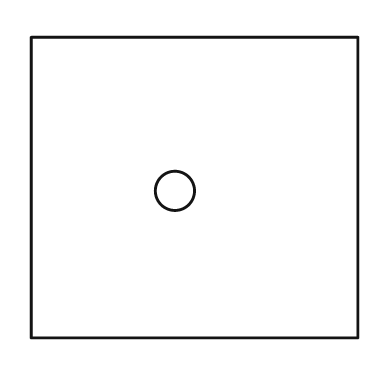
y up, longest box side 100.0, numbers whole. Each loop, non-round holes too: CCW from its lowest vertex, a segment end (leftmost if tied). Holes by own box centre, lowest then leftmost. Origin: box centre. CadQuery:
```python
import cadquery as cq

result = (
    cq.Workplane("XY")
    .moveTo(-50.0, -46.0)
    .lineTo(50.0, -46.0)
    .lineTo(50.0, 46.0)
    .lineTo(-50.0, 46.0)
    .close()
    .moveTo(-6.0, -1.0)
    .circle(6.0)
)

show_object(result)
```